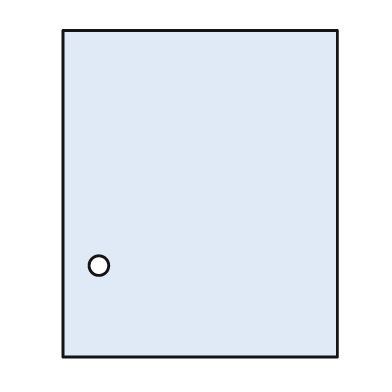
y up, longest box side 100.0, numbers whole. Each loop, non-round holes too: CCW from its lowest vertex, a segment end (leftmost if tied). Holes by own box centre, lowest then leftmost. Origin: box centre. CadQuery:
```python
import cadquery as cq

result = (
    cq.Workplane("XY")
    .moveTo(-42.0, -50.0)
    .lineTo(42.0, -50.0)
    .lineTo(42.0, 50.0)
    .lineTo(-42.0, 50.0)
    .close()
    .moveTo(-31.0, -22.0)
    .circle(3.0)
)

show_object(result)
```